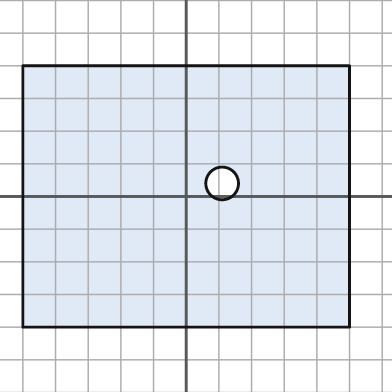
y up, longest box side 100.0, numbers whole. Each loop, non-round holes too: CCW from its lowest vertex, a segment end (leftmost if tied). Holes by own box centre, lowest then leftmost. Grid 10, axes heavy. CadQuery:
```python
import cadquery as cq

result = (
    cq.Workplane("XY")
    .moveTo(-50.0, -40.0)
    .lineTo(50.0, -40.0)
    .lineTo(50.0, 40.0)
    .lineTo(-50.0, 40.0)
    .close()
    .moveTo(11.0, 4.0)
    .circle(5.0)
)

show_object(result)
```